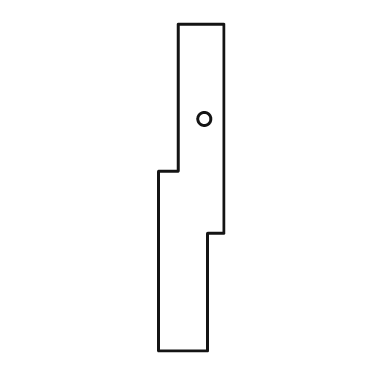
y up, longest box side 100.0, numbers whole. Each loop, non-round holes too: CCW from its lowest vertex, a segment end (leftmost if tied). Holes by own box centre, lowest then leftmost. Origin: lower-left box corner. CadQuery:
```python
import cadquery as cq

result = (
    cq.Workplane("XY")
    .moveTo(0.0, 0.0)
    .lineTo(15.0, 0.0)
    .lineTo(15.0, 36.0)
    .lineTo(20.0, 36.0)
    .lineTo(20.0, 100.0)
    .lineTo(6.0, 100.0)
    .lineTo(6.0, 55.0)
    .lineTo(0.0, 55.0)
    .close()
    .moveTo(14.0, 71.0)
    .circle(2.0)
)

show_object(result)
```